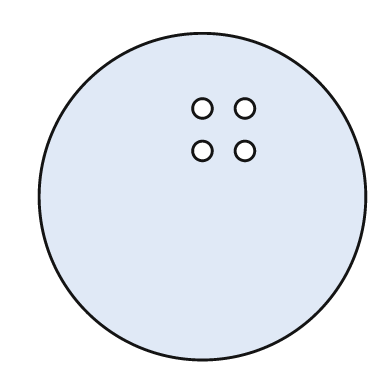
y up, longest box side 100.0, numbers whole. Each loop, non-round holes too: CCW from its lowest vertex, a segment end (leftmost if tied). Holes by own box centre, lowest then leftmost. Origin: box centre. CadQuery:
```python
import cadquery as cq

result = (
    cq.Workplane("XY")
    .moveTo(0.0, 0.0)
    .circle(50.0)
    .moveTo(0.0, 14.0)
    .circle(3.0)
    .moveTo(13.0, 14.0)
    .circle(3.0)
    .moveTo(0.0, 27.0)
    .circle(3.0)
    .moveTo(13.0, 27.0)
    .circle(3.0)
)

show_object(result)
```